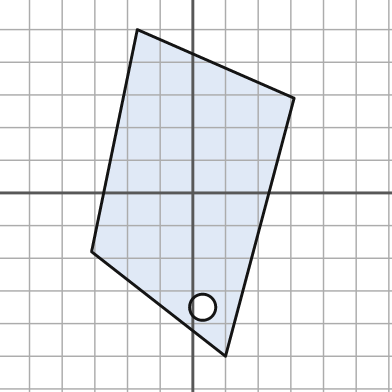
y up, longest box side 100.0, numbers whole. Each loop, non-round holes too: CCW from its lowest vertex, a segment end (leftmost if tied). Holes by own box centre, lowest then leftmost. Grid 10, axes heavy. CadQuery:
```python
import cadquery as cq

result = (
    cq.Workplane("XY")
    .moveTo(10.0, -50.0)
    .lineTo(31.0, 29.0)
    .lineTo(-17.0, 50.0)
    .lineTo(-31.0, -18.0)
    .close()
    .moveTo(3.0, -35.0)
    .circle(4.0)
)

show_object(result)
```